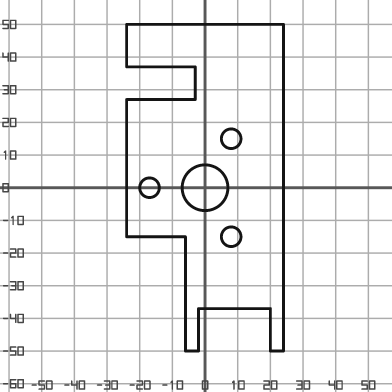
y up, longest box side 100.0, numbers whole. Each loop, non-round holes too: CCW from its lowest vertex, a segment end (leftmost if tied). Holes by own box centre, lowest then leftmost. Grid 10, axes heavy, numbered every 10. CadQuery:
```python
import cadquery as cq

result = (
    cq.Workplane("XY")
    .moveTo(-6.0, -50.0)
    .lineTo(-2.0, -50.0)
    .lineTo(-2.0, -37.0)
    .lineTo(20.0, -37.0)
    .lineTo(20.0, -50.0)
    .lineTo(24.0, -50.0)
    .lineTo(24.0, 50.0)
    .lineTo(-24.0, 50.0)
    .lineTo(-24.0, 37.0)
    .lineTo(-3.0, 37.0)
    .lineTo(-3.0, 27.0)
    .lineTo(-24.0, 27.0)
    .lineTo(-24.0, -15.0)
    .lineTo(-6.0, -15.0)
    .close()
    .moveTo(8.0, -15.0)
    .circle(3.0)
    .moveTo(-17.0, 0.0)
    .circle(3.0)
    .moveTo(0.0, 0.0)
    .circle(7.0)
    .moveTo(8.0, 15.0)
    .circle(3.0)
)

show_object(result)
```